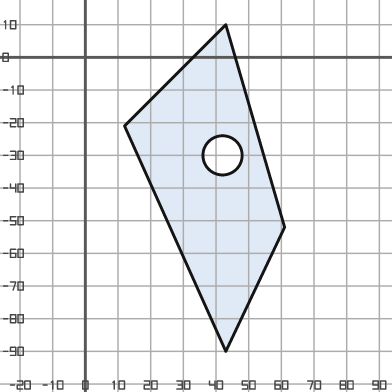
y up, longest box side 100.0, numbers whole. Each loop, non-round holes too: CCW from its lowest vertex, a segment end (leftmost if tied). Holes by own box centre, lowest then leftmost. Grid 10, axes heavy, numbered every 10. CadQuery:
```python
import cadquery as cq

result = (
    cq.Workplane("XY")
    .moveTo(43.0, -90.0)
    .lineTo(61.0, -52.0)
    .lineTo(43.0, 10.0)
    .lineTo(12.0, -21.0)
    .close()
    .moveTo(42.0, -30.0)
    .circle(6.0)
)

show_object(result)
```